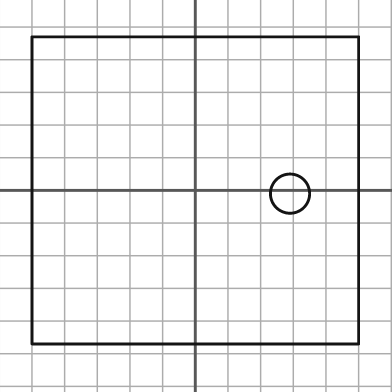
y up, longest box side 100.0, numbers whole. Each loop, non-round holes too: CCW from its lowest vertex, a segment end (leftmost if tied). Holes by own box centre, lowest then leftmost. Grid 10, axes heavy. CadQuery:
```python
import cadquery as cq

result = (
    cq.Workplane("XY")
    .moveTo(-50.0, -47.0)
    .lineTo(50.0, -47.0)
    .lineTo(50.0, 47.0)
    .lineTo(-50.0, 47.0)
    .close()
    .moveTo(29.0, -1.0)
    .circle(6.0)
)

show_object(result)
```